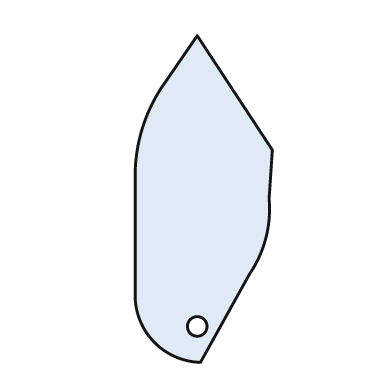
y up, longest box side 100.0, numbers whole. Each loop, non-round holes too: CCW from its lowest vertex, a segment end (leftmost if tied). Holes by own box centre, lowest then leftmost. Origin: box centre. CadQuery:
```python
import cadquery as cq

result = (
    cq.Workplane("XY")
    .moveTo(-1.0, -50.0)
    .lineTo(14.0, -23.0)
    .threePointArc((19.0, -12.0), (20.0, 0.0))
    .lineTo(21.0, 15.0)
    .lineTo(-2.0, 50.0)
    .lineTo(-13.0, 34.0)
    .threePointArc((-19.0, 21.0), (-21.0, 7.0))
    .lineTo(-21.0, -30.0)
    .threePointArc((-15.0, -44.0), (-1.0, -50.0))
    .close()
    .moveTo(-2.0, -39.0)
    .circle(3.0)
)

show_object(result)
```